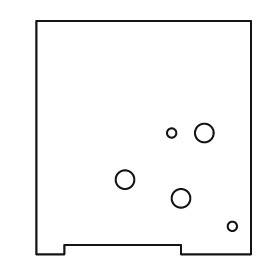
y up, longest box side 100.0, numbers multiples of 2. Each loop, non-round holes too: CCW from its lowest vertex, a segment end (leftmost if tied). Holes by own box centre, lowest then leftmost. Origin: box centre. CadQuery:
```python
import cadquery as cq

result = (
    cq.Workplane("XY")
    .moveTo(-46.0, -50.0)
    .lineTo(-34.0, -50.0)
    .lineTo(-34.0, -46.0)
    .lineTo(16.0, -46.0)
    .lineTo(16.0, -50.0)
    .lineTo(46.0, -50.0)
    .lineTo(46.0, 50.0)
    .lineTo(-46.0, 50.0)
    .close()
    .moveTo(38.0, -38.0)
    .circle(2.0)
    .moveTo(16.0, -26.0)
    .circle(4.0)
    .moveTo(-8.0, -18.0)
    .circle(4.0)
    .moveTo(12.0, 2.0)
    .circle(2.0)
    .moveTo(26.0, 2.0)
    .circle(4.0)
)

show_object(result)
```